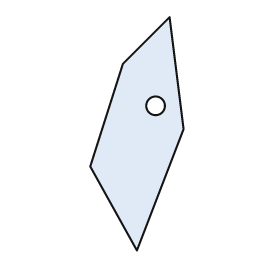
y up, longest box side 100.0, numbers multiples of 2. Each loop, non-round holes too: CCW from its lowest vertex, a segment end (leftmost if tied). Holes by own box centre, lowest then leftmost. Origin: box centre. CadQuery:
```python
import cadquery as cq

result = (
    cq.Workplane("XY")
    .moveTo(0.0, -50.0)
    .lineTo(20.0, 2.0)
    .lineTo(14.0, 50.0)
    .lineTo(-6.0, 30.0)
    .lineTo(-20.0, -14.0)
    .close()
    .moveTo(8.0, 12.0)
    .circle(4.0)
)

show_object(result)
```